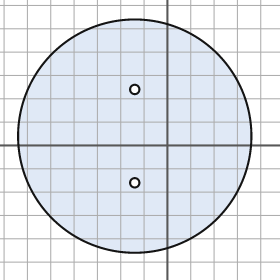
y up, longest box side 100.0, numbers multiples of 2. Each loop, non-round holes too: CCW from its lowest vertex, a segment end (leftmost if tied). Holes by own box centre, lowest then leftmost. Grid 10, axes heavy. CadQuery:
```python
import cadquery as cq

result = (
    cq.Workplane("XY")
    .moveTo(-14.0, 4.0)
    .circle(50.0)
    .moveTo(-14.0, -16.0)
    .circle(2.0)
    .moveTo(-14.0, 24.0)
    .circle(2.0)
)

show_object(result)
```